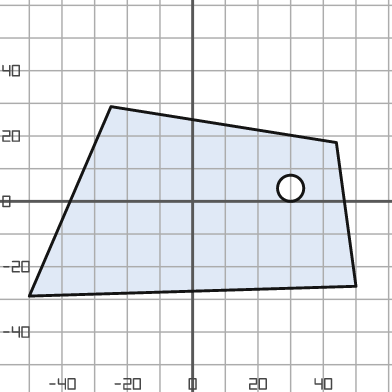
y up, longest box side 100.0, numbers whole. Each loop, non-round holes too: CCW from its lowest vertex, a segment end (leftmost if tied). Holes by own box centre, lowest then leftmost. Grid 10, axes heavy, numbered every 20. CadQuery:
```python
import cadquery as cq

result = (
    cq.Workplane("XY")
    .moveTo(-50.0, -29.0)
    .lineTo(50.0, -26.0)
    .lineTo(44.0, 18.0)
    .lineTo(-25.0, 29.0)
    .close()
    .moveTo(30.0, 4.0)
    .circle(4.0)
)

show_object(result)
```